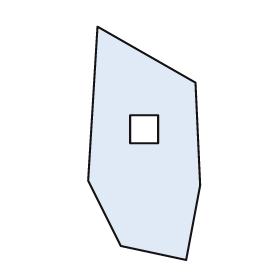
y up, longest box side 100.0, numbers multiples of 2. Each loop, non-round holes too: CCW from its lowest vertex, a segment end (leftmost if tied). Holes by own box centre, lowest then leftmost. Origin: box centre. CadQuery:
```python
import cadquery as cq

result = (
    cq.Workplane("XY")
    .moveTo(18.0, -50.0)
    .lineTo(24.0, -18.0)
    .lineTo(22.0, 26.0)
    .lineTo(-20.0, 50.0)
    .lineTo(-24.0, -16.0)
    .lineTo(-10.0, -44.0)
    .close()
    .moveTo(-6.0, 0.0)
    .lineTo(6.0, 0.0)
    .lineTo(6.0, 12.0)
    .lineTo(-6.0, 12.0)
    .close()
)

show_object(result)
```